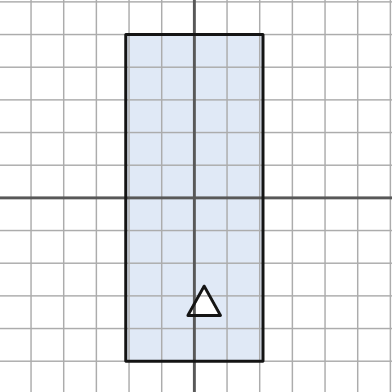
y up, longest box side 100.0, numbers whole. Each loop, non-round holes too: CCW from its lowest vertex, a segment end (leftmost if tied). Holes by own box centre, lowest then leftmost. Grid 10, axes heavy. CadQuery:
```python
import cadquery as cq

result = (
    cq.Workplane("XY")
    .moveTo(-21.0, -50.0)
    .lineTo(21.0, -50.0)
    .lineTo(21.0, 50.0)
    .lineTo(-21.0, 50.0)
    .close()
    .moveTo(-2.0, -36.0)
    .lineTo(8.0, -36.0)
    .lineTo(3.0, -27.0)
    .close()
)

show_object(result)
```